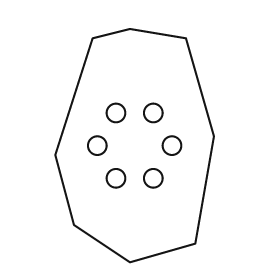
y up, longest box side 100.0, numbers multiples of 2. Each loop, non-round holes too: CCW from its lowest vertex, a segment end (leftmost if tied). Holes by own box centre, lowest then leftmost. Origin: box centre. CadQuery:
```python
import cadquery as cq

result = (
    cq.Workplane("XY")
    .moveTo(-2.0, -50.0)
    .lineTo(26.0, -42.0)
    .lineTo(34.0, 4.0)
    .lineTo(22.0, 46.0)
    .lineTo(-2.0, 50.0)
    .lineTo(-18.0, 46.0)
    .lineTo(-34.0, -4.0)
    .lineTo(-26.0, -34.0)
    .close()
    .moveTo(-8.0, -14.0)
    .circle(4.0)
    .moveTo(8.0, -14.0)
    .circle(4.0)
    .moveTo(-16.0, 0.0)
    .circle(4.0)
    .moveTo(16.0, 0.0)
    .circle(4.0)
    .moveTo(-8.0, 14.0)
    .circle(4.0)
    .moveTo(8.0, 14.0)
    .circle(4.0)
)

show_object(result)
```